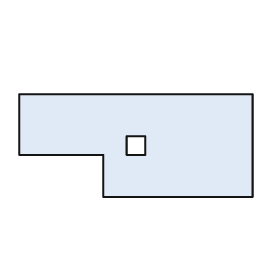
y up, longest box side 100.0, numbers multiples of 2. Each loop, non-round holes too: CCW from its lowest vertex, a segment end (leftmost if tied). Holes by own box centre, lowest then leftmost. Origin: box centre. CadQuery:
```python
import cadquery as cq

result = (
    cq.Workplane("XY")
    .moveTo(-14.0, -22.0)
    .lineTo(50.0, -22.0)
    .lineTo(50.0, 22.0)
    .lineTo(-50.0, 22.0)
    .lineTo(-50.0, -4.0)
    .lineTo(-14.0, -4.0)
    .close()
    .moveTo(-4.0, -4.0)
    .lineTo(4.0, -4.0)
    .lineTo(4.0, 4.0)
    .lineTo(-4.0, 4.0)
    .close()
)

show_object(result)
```